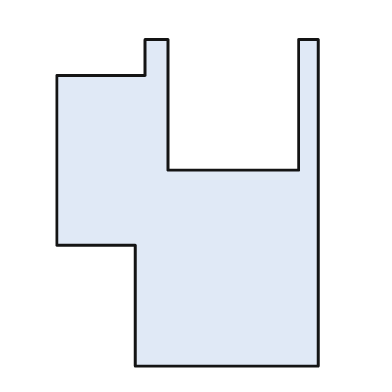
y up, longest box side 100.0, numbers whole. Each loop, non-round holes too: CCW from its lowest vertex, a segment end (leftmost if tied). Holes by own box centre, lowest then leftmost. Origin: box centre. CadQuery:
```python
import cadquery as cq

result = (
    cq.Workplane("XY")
    .moveTo(-16.0, -50.0)
    .lineTo(40.0, -50.0)
    .lineTo(40.0, 50.0)
    .lineTo(34.0, 50.0)
    .lineTo(34.0, 10.0)
    .lineTo(-6.0, 10.0)
    .lineTo(-6.0, 50.0)
    .lineTo(-13.0, 50.0)
    .lineTo(-13.0, 39.0)
    .lineTo(-40.0, 39.0)
    .lineTo(-40.0, -13.0)
    .lineTo(-16.0, -13.0)
    .close()
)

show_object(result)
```